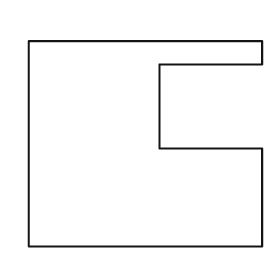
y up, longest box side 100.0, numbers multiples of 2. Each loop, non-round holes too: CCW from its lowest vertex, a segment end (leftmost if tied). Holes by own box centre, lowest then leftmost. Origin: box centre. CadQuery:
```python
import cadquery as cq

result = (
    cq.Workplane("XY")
    .moveTo(-50.0, -44.0)
    .lineTo(50.0, -44.0)
    .lineTo(50.0, -2.0)
    .lineTo(6.0, -2.0)
    .lineTo(6.0, 34.0)
    .lineTo(50.0, 34.0)
    .lineTo(50.0, 44.0)
    .lineTo(-50.0, 44.0)
    .close()
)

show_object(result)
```